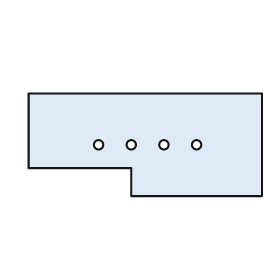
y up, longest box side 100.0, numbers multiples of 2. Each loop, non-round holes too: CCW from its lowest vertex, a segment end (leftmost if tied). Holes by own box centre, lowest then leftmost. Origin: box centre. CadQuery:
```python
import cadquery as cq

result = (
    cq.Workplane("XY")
    .moveTo(-6.0, -22.0)
    .lineTo(50.0, -22.0)
    .lineTo(50.0, 22.0)
    .lineTo(-50.0, 22.0)
    .lineTo(-50.0, -10.0)
    .lineTo(-6.0, -10.0)
    .close()
    .moveTo(-20.0, 0.0)
    .circle(2.0)
    .moveTo(-6.0, 0.0)
    .circle(2.0)
    .moveTo(8.0, 0.0)
    .circle(2.0)
    .moveTo(22.0, 0.0)
    .circle(2.0)
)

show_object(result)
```